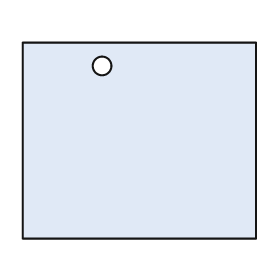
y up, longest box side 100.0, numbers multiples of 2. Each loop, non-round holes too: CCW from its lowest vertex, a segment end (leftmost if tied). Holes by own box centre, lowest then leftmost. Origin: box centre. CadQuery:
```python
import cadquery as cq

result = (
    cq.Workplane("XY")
    .moveTo(-50.0, -42.0)
    .lineTo(50.0, -42.0)
    .lineTo(50.0, 42.0)
    .lineTo(-50.0, 42.0)
    .close()
    .moveTo(-16.0, 32.0)
    .circle(4.0)
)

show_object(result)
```